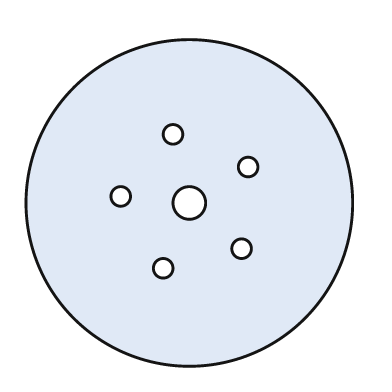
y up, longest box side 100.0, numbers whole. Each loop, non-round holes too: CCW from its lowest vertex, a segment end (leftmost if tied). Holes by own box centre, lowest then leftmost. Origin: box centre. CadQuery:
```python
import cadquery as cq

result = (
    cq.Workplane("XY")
    .moveTo(0.0, 0.0)
    .circle(50.0)
    .moveTo(-8.0, -20.0)
    .circle(3.0)
    .moveTo(16.0, -14.0)
    .circle(3.0)
    .moveTo(0.0, 0.0)
    .circle(5.0)
    .moveTo(-21.0, 2.0)
    .circle(3.0)
    .moveTo(18.0, 11.0)
    .circle(3.0)
    .moveTo(-5.0, 21.0)
    .circle(3.0)
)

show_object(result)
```